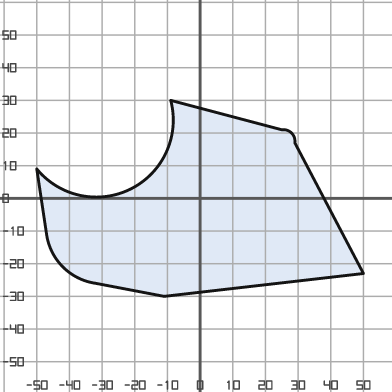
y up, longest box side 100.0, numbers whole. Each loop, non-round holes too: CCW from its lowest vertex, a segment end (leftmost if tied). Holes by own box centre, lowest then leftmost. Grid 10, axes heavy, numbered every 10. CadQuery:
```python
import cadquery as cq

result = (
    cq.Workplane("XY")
    .moveTo(-11.0, -30.0)
    .lineTo(50.0, -23.0)
    .lineTo(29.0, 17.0)
    .threePointArc((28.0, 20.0), (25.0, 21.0))
    .lineTo(-9.0, 30.0)
    .threePointArc((-21.0, 3.0), (-50.0, 9.0))
    .lineTo(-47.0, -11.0)
    .threePointArc((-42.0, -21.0), (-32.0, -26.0))
    .close()
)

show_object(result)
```